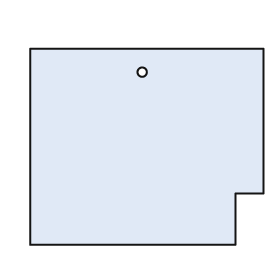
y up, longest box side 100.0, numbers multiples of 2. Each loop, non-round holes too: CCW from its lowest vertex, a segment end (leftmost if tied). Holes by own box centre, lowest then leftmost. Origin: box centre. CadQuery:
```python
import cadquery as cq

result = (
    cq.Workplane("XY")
    .moveTo(-50.0, -42.0)
    .lineTo(38.0, -42.0)
    .lineTo(38.0, -20.0)
    .lineTo(50.0, -20.0)
    .lineTo(50.0, 42.0)
    .lineTo(-50.0, 42.0)
    .close()
    .moveTo(-2.0, 32.0)
    .circle(2.0)
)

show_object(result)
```